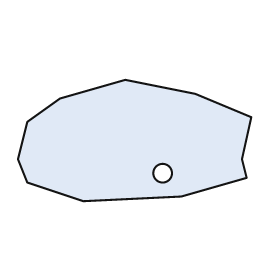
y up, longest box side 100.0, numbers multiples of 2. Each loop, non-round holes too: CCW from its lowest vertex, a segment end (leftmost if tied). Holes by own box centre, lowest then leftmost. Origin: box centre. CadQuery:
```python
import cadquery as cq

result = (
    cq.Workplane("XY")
    .moveTo(-22.0, -26.0)
    .lineTo(20.0, -24.0)
    .lineTo(48.0, -16.0)
    .lineTo(46.0, -8.0)
    .lineTo(50.0, 10.0)
    .lineTo(26.0, 20.0)
    .lineTo(-4.0, 26.0)
    .lineTo(-32.0, 18.0)
    .lineTo(-46.0, 8.0)
    .lineTo(-50.0, -8.0)
    .lineTo(-46.0, -18.0)
    .close()
    .moveTo(12.0, -14.0)
    .circle(4.0)
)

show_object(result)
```